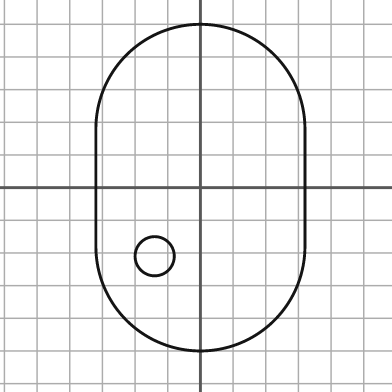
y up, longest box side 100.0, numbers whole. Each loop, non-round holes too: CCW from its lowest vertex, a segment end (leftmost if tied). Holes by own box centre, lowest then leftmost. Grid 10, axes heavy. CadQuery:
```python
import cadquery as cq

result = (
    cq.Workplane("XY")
    .moveTo(-32.0, -18.0)
    .threePointArc((0.0, -50.0), (32.0, -18.0))
    .lineTo(32.0, 18.0)
    .threePointArc((0.0, 50.0), (-32.0, 18.0))
    .close()
    .moveTo(-14.0, -21.0)
    .circle(6.0)
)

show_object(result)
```